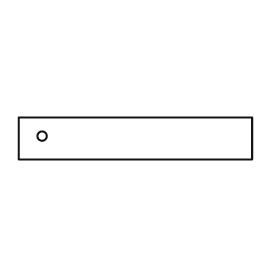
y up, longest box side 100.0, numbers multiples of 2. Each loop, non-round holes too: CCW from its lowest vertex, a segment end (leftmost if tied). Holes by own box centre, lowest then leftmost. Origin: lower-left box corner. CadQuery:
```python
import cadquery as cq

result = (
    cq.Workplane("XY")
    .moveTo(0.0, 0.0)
    .lineTo(100.0, 0.0)
    .lineTo(100.0, 18.0)
    .lineTo(0.0, 18.0)
    .close()
    .moveTo(10.0, 10.0)
    .circle(2.0)
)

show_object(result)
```